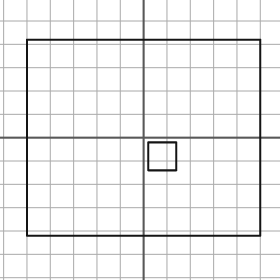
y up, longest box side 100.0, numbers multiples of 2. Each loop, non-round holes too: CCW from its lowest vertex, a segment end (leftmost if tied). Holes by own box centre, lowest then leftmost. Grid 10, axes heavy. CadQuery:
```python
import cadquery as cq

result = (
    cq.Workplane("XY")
    .moveTo(-50.0, -42.0)
    .lineTo(50.0, -42.0)
    .lineTo(50.0, 42.0)
    .lineTo(-50.0, 42.0)
    .close()
    .moveTo(2.0, -14.0)
    .lineTo(14.0, -14.0)
    .lineTo(14.0, -2.0)
    .lineTo(2.0, -2.0)
    .close()
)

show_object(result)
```